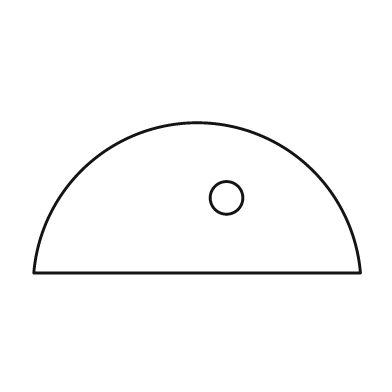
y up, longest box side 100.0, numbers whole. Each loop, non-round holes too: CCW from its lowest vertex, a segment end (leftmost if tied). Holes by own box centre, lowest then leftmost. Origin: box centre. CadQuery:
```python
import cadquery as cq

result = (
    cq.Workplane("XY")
    .moveTo(-50.0, -23.0)
    .lineTo(50.0, -23.0)
    .threePointArc((0.0, 23.0), (-50.0, -23.0))
    .close()
    .moveTo(9.0, 0.0)
    .circle(5.0)
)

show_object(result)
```